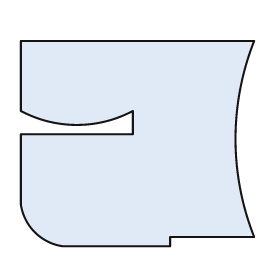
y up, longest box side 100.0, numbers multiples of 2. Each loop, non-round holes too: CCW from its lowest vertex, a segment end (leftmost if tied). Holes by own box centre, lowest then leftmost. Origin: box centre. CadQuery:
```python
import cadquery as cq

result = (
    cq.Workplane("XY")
    .moveTo(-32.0, -44.0)
    .lineTo(14.0, -44.0)
    .lineTo(14.0, -40.0)
    .lineTo(50.0, -40.0)
    .threePointArc((42.0, 2.0), (50.0, 44.0))
    .lineTo(-50.0, 44.0)
    .lineTo(-50.0, 14.0)
    .threePointArc((-26.0, 8.0), (-2.0, 14.0))
    .lineTo(-2.0, 4.0)
    .lineTo(-50.0, 4.0)
    .lineTo(-50.0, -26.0)
    .threePointArc((-44.0, -38.0), (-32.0, -44.0))
    .close()
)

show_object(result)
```